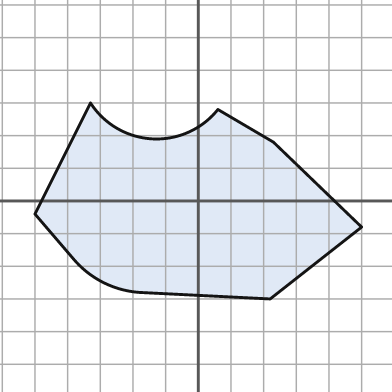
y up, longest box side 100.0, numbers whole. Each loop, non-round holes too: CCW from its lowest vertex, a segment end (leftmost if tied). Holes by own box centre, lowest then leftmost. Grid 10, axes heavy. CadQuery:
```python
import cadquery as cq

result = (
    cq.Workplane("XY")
    .moveTo(22.0, -30.0)
    .lineTo(50.0, -8.0)
    .lineTo(23.0, 18.0)
    .lineTo(6.0, 28.0)
    .threePointArc((-14.0, 19.0), (-33.0, 30.0))
    .lineTo(-50.0, -4.0)
    .lineTo(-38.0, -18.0)
    .threePointArc((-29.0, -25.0), (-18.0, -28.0))
    .close()
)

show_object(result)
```